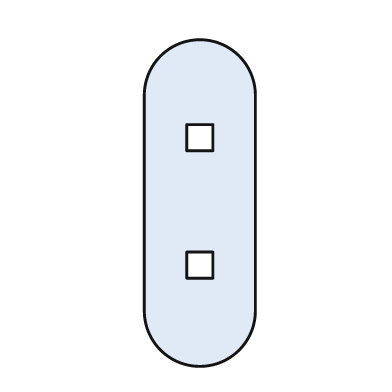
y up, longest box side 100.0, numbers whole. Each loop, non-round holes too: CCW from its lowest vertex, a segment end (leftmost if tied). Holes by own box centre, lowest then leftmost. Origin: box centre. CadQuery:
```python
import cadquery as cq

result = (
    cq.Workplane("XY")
    .moveTo(-17.0, -33.0)
    .threePointArc((0.0, -50.0), (17.0, -33.0))
    .lineTo(17.0, 33.0)
    .threePointArc((0.0, 50.0), (-17.0, 33.0))
    .close()
    .moveTo(-4.0, -23.0)
    .lineTo(4.0, -23.0)
    .lineTo(4.0, -15.0)
    .lineTo(-4.0, -15.0)
    .close()
    .moveTo(-4.0, 16.0)
    .lineTo(4.0, 16.0)
    .lineTo(4.0, 24.0)
    .lineTo(-4.0, 24.0)
    .close()
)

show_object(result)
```